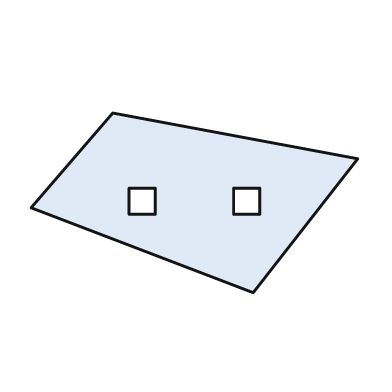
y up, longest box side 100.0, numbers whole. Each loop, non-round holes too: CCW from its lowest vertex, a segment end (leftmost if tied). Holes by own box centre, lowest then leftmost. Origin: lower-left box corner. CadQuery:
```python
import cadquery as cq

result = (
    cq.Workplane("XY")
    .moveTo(68.0, 0.0)
    .lineTo(100.0, 41.0)
    .lineTo(25.0, 55.0)
    .lineTo(0.0, 26.0)
    .close()
    .moveTo(30.0, 24.0)
    .lineTo(38.0, 24.0)
    .lineTo(38.0, 32.0)
    .lineTo(30.0, 32.0)
    .close()
    .moveTo(62.0, 24.0)
    .lineTo(70.0, 24.0)
    .lineTo(70.0, 32.0)
    .lineTo(62.0, 32.0)
    .close()
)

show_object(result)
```